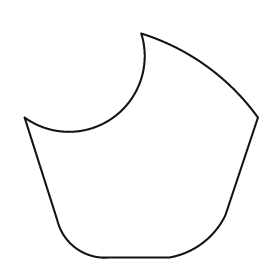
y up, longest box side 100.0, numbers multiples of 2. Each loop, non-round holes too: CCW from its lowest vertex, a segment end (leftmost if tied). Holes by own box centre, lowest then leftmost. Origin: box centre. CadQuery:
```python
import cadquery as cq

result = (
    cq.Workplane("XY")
    .moveTo(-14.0, -48.0)
    .lineTo(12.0, -48.0)
    .threePointArc((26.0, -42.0), (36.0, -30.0))
    .lineTo(50.0, 12.0)
    .threePointArc((28.0, 34.0), (0.0, 48.0))
    .threePointArc((-12.0, 12.0), (-50.0, 12.0))
    .lineTo(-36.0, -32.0)
    .threePointArc((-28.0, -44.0), (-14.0, -48.0))
    .close()
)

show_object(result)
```